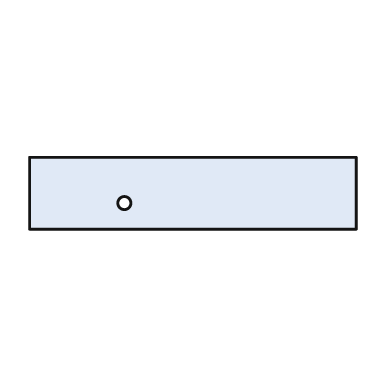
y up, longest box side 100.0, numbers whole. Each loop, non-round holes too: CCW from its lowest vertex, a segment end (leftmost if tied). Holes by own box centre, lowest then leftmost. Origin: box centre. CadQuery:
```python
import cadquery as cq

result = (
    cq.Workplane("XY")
    .moveTo(-50.0, -11.0)
    .lineTo(50.0, -11.0)
    .lineTo(50.0, 11.0)
    .lineTo(-50.0, 11.0)
    .close()
    .moveTo(-21.0, -3.0)
    .circle(2.0)
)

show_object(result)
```